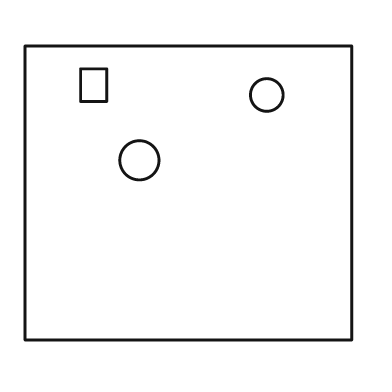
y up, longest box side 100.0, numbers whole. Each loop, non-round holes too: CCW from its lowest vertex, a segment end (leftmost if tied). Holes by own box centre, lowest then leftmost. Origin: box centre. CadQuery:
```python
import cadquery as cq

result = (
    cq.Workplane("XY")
    .moveTo(-50.0, -45.0)
    .lineTo(50.0, -45.0)
    .lineTo(50.0, 45.0)
    .lineTo(-50.0, 45.0)
    .close()
    .moveTo(-15.0, 10.0)
    .circle(6.0)
    .moveTo(24.0, 30.0)
    .circle(5.0)
    .moveTo(-33.0, 28.0)
    .lineTo(-25.0, 28.0)
    .lineTo(-25.0, 38.0)
    .lineTo(-33.0, 38.0)
    .close()
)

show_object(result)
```